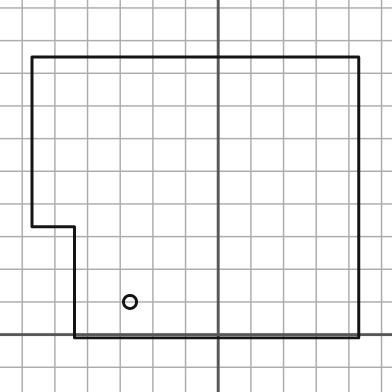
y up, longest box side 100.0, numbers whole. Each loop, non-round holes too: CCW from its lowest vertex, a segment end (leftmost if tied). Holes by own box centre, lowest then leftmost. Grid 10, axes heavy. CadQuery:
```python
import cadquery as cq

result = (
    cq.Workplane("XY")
    .moveTo(-44.0, -1.0)
    .lineTo(43.0, -1.0)
    .lineTo(43.0, 85.0)
    .lineTo(-57.0, 85.0)
    .lineTo(-57.0, 33.0)
    .lineTo(-44.0, 33.0)
    .close()
    .moveTo(-27.0, 10.0)
    .circle(2.0)
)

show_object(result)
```